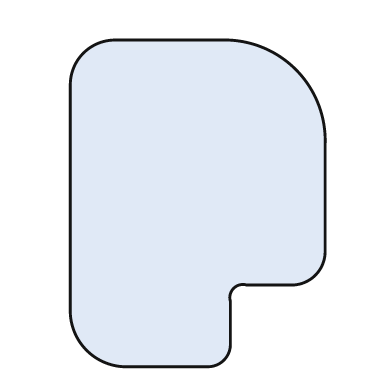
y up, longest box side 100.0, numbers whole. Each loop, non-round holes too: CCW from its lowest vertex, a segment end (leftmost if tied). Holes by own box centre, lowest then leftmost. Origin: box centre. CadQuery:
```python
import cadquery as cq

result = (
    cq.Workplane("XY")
    .moveTo(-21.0, -50.0)
    .lineTo(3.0, -50.0)
    .threePointArc((8.0, -48.0), (10.0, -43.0))
    .lineTo(10.0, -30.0)
    .threePointArc((11.0, -26.0), (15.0, -25.0))
    .lineTo(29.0, -25.0)
    .threePointArc((36.0, -22.0), (39.0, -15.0))
    .lineTo(39.0, 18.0)
    .threePointArc((30.0, 41.0), (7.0, 50.0))
    .lineTo(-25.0, 50.0)
    .threePointArc((-35.0, 46.0), (-39.0, 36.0))
    .lineTo(-39.0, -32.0)
    .threePointArc((-34.0, -45.0), (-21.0, -50.0))
    .close()
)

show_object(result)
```